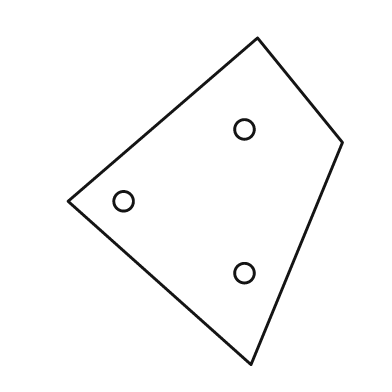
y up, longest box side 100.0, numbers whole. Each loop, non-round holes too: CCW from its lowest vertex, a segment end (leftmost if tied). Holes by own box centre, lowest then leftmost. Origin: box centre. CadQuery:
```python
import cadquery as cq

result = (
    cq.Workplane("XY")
    .moveTo(14.0, -50.0)
    .lineTo(42.0, 18.0)
    .lineTo(16.0, 50.0)
    .lineTo(-42.0, 0.0)
    .close()
    .moveTo(12.0, -22.0)
    .circle(3.0)
    .moveTo(-25.0, 0.0)
    .circle(3.0)
    .moveTo(12.0, 22.0)
    .circle(3.0)
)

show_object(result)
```